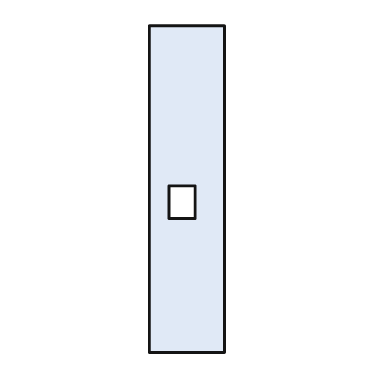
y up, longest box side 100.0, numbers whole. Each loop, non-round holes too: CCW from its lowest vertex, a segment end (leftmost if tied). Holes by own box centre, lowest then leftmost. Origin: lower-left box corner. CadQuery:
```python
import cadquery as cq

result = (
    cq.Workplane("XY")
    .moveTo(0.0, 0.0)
    .lineTo(23.0, 0.0)
    .lineTo(23.0, 100.0)
    .lineTo(0.0, 100.0)
    .close()
    .moveTo(6.0, 41.0)
    .lineTo(14.0, 41.0)
    .lineTo(14.0, 51.0)
    .lineTo(6.0, 51.0)
    .close()
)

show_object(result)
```